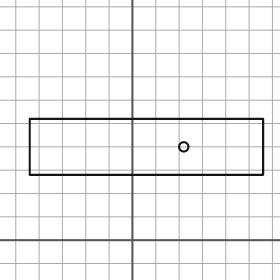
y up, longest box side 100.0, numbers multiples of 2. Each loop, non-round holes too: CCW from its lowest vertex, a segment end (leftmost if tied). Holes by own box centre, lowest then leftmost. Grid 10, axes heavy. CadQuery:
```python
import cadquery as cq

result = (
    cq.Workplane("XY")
    .moveTo(-44.0, 28.0)
    .lineTo(56.0, 28.0)
    .lineTo(56.0, 52.0)
    .lineTo(-44.0, 52.0)
    .close()
    .moveTo(22.0, 40.0)
    .circle(2.0)
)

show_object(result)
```